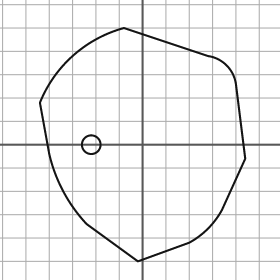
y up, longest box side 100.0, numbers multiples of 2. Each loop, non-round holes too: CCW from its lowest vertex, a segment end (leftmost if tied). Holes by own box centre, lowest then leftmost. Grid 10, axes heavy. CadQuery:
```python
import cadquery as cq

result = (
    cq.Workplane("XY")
    .moveTo(-2.0, -50.0)
    .lineTo(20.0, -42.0)
    .threePointArc((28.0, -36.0), (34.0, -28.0))
    .lineTo(44.0, -6.0)
    .lineTo(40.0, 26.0)
    .threePointArc((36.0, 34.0), (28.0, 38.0))
    .lineTo(-8.0, 50.0)
    .threePointArc((-30.0, 38.0), (-44.0, 18.0))
    .lineTo(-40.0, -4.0)
    .threePointArc((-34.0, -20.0), (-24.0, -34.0))
    .close()
    .moveTo(-22.0, 0.0)
    .circle(4.0)
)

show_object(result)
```